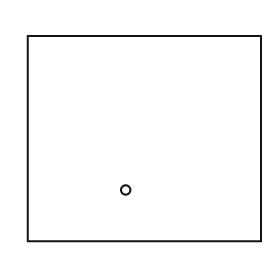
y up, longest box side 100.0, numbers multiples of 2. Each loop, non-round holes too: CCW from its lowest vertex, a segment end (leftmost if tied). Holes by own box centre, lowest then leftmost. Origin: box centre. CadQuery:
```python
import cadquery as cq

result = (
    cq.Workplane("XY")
    .moveTo(-50.0, -44.0)
    .lineTo(50.0, -44.0)
    .lineTo(50.0, 44.0)
    .lineTo(-50.0, 44.0)
    .close()
    .moveTo(-8.0, -22.0)
    .circle(2.0)
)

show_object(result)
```